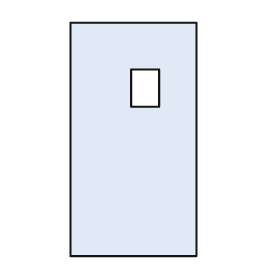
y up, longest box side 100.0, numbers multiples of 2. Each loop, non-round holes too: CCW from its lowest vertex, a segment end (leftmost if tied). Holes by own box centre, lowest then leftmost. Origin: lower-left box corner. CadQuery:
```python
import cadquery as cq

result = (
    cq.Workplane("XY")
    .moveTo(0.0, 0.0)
    .lineTo(54.0, 0.0)
    .lineTo(54.0, 100.0)
    .lineTo(0.0, 100.0)
    .close()
    .moveTo(26.0, 64.0)
    .lineTo(38.0, 64.0)
    .lineTo(38.0, 80.0)
    .lineTo(26.0, 80.0)
    .close()
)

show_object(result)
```